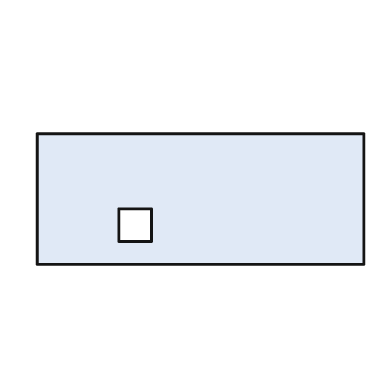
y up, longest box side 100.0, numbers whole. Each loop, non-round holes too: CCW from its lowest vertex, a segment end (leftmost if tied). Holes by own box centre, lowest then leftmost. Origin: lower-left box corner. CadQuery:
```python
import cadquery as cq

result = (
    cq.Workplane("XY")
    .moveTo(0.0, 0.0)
    .lineTo(100.0, 0.0)
    .lineTo(100.0, 40.0)
    .lineTo(0.0, 40.0)
    .close()
    .moveTo(25.0, 7.0)
    .lineTo(35.0, 7.0)
    .lineTo(35.0, 17.0)
    .lineTo(25.0, 17.0)
    .close()
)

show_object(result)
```